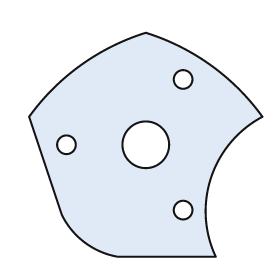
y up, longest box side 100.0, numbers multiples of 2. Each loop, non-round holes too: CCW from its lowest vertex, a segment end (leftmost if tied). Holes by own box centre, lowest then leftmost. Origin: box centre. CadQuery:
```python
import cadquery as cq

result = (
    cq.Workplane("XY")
    .moveTo(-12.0, -48.0)
    .lineTo(30.0, -48.0)
    .threePointArc((28.0, -14.0), (50.0, 12.0))
    .threePointArc((28.0, 34.0), (0.0, 48.0))
    .threePointArc((-28.0, 34.0), (-50.0, 12.0))
    .lineTo(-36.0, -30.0)
    .threePointArc((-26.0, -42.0), (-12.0, -48.0))
    .close()
    .moveTo(16.0, -28.0)
    .circle(4.0)
    .moveTo(-34.0, 0.0)
    .circle(4.0)
    .moveTo(0.0, 0.0)
    .circle(10.0)
    .moveTo(16.0, 28.0)
    .circle(4.0)
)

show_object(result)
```